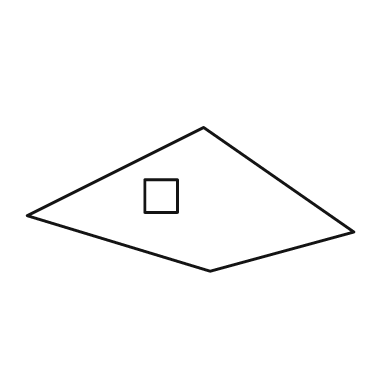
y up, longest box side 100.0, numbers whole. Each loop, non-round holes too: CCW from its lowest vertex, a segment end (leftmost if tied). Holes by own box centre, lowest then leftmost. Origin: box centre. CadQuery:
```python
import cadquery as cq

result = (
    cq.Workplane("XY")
    .moveTo(6.0, -22.0)
    .lineTo(50.0, -10.0)
    .lineTo(4.0, 22.0)
    .lineTo(-50.0, -5.0)
    .close()
    .moveTo(-14.0, -4.0)
    .lineTo(-4.0, -4.0)
    .lineTo(-4.0, 6.0)
    .lineTo(-14.0, 6.0)
    .close()
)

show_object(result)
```